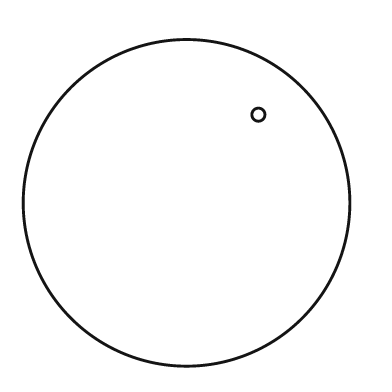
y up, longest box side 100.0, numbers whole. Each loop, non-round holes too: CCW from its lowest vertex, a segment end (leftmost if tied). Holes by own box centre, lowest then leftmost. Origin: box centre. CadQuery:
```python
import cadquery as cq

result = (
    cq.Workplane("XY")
    .moveTo(0.0, 0.0)
    .circle(50.0)
    .moveTo(22.0, 27.0)
    .circle(2.0)
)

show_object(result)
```